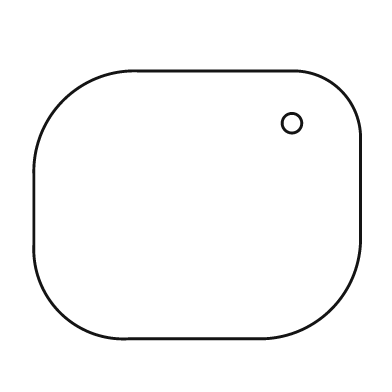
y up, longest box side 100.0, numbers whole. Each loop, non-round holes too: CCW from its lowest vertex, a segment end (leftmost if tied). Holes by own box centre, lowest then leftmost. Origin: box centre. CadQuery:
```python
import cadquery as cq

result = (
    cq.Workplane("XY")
    .moveTo(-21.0, -41.0)
    .lineTo(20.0, -41.0)
    .threePointArc((41.0, -32.0), (50.0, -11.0))
    .lineTo(50.0, 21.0)
    .threePointArc((44.0, 35.0), (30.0, 41.0))
    .lineTo(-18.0, 41.0)
    .threePointArc((-41.0, 32.0), (-50.0, 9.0))
    .lineTo(-50.0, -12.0)
    .threePointArc((-42.0, -33.0), (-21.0, -41.0))
    .close()
    .moveTo(29.0, 25.0)
    .circle(3.0)
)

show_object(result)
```